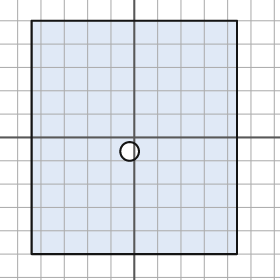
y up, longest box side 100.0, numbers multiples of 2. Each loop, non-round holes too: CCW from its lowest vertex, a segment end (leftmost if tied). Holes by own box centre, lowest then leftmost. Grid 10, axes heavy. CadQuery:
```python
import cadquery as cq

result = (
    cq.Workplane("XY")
    .moveTo(-44.0, -50.0)
    .lineTo(44.0, -50.0)
    .lineTo(44.0, 50.0)
    .lineTo(-44.0, 50.0)
    .close()
    .moveTo(-2.0, -6.0)
    .circle(4.0)
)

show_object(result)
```